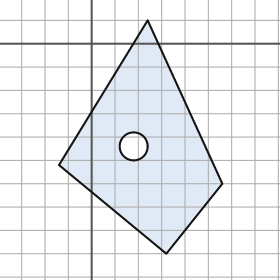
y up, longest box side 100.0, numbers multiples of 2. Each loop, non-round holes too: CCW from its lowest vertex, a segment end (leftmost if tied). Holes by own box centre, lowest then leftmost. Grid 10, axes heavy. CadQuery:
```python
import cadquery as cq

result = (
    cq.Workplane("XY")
    .moveTo(32.0, -90.0)
    .lineTo(56.0, -60.0)
    .lineTo(24.0, 10.0)
    .lineTo(-14.0, -52.0)
    .close()
    .moveTo(18.0, -44.0)
    .circle(6.0)
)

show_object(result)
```